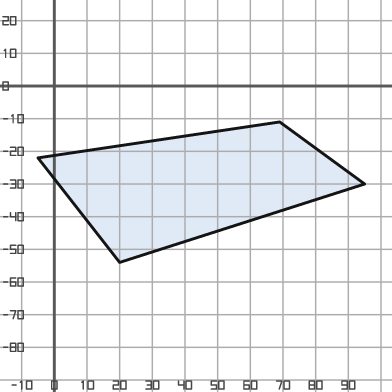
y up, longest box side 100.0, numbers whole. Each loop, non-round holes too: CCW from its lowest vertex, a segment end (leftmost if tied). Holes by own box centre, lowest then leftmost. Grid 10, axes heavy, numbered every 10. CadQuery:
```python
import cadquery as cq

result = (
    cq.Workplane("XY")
    .moveTo(20.0, -54.0)
    .lineTo(95.0, -30.0)
    .lineTo(69.0, -11.0)
    .lineTo(-5.0, -22.0)
    .close()
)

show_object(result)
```